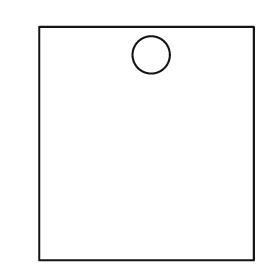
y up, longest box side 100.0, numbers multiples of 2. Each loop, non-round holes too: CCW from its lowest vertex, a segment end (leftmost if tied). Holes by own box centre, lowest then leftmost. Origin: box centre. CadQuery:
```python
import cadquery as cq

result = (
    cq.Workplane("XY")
    .moveTo(-46.0, -50.0)
    .lineTo(46.0, -50.0)
    .lineTo(46.0, 50.0)
    .lineTo(-46.0, 50.0)
    .close()
    .moveTo(2.0, 38.0)
    .circle(8.0)
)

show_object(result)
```